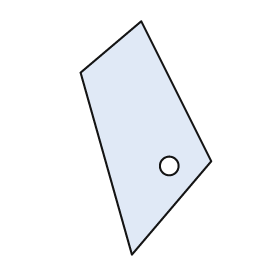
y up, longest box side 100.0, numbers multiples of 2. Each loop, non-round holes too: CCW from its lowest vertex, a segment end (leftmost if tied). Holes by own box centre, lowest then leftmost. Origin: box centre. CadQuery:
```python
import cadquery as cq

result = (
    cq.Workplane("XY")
    .moveTo(-6.0, -50.0)
    .lineTo(28.0, -10.0)
    .lineTo(-2.0, 50.0)
    .lineTo(-28.0, 28.0)
    .close()
    .moveTo(10.0, -12.0)
    .circle(4.0)
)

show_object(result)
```